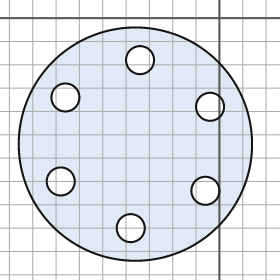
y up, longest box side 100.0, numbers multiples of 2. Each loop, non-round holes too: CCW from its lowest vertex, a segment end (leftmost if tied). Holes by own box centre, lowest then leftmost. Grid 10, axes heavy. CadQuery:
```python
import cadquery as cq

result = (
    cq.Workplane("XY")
    .moveTo(-36.0, -54.0)
    .circle(50.0)
    .moveTo(-38.0, -90.0)
    .circle(6.0)
    .moveTo(-6.0, -74.0)
    .circle(6.0)
    .moveTo(-68.0, -70.0)
    .circle(6.0)
    .moveTo(-4.0, -38.0)
    .circle(6.0)
    .moveTo(-66.0, -34.0)
    .circle(6.0)
    .moveTo(-34.0, -18.0)
    .circle(6.0)
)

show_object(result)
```